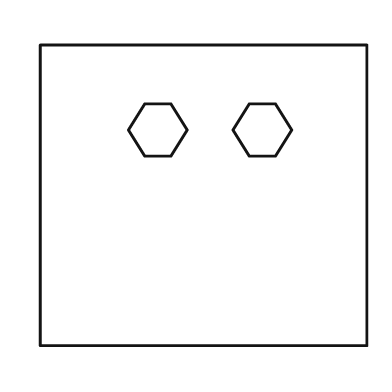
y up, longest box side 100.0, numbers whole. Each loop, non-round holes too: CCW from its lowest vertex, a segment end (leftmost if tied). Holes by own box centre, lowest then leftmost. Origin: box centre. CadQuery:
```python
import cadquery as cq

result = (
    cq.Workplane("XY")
    .moveTo(-50.0, -46.0)
    .lineTo(50.0, -46.0)
    .lineTo(50.0, 46.0)
    .lineTo(-50.0, 46.0)
    .close()
    .moveTo(-18.0, 12.0)
    .lineTo(-10.0, 12.0)
    .lineTo(-5.0, 20.0)
    .lineTo(-10.0, 28.0)
    .lineTo(-18.0, 28.0)
    .lineTo(-23.0, 20.0)
    .close()
    .moveTo(14.0, 12.0)
    .lineTo(22.0, 12.0)
    .lineTo(27.0, 20.0)
    .lineTo(22.0, 28.0)
    .lineTo(14.0, 28.0)
    .lineTo(9.0, 20.0)
    .close()
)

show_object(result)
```